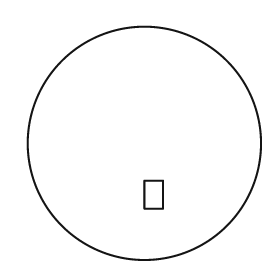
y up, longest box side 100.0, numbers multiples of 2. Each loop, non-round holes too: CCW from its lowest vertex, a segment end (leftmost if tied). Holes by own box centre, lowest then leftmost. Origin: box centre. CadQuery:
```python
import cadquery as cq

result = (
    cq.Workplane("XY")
    .moveTo(0.0, 0.0)
    .circle(50.0)
    .moveTo(0.0, -28.0)
    .lineTo(8.0, -28.0)
    .lineTo(8.0, -16.0)
    .lineTo(0.0, -16.0)
    .close()
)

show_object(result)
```